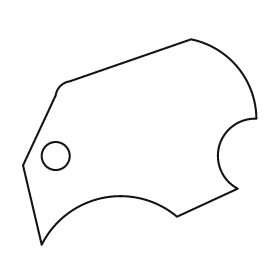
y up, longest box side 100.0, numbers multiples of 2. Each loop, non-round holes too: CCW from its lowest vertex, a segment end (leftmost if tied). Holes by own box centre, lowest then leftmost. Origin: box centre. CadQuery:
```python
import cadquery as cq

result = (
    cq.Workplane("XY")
    .moveTo(-42.0, -44.0)
    .threePointArc((-16.0, -24.0), (16.0, -32.0))
    .lineTo(42.0, -20.0)
    .threePointArc((34.0, -2.0), (50.0, 10.0))
    .threePointArc((42.0, 32.0), (22.0, 44.0))
    .lineTo(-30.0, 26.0)
    .threePointArc((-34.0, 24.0), (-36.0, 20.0))
    .lineTo(-50.0, -10.0)
    .close()
    .moveTo(-36.0, -6.0)
    .circle(6.0)
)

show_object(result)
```